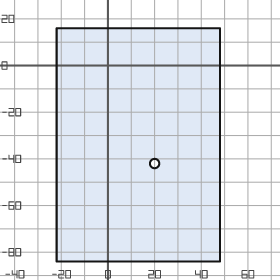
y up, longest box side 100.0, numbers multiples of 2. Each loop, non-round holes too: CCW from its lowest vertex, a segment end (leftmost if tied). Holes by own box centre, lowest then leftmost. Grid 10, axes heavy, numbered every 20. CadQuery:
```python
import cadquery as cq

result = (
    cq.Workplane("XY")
    .moveTo(-22.0, -84.0)
    .lineTo(48.0, -84.0)
    .lineTo(48.0, 16.0)
    .lineTo(-22.0, 16.0)
    .close()
    .moveTo(20.0, -42.0)
    .circle(2.0)
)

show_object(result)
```